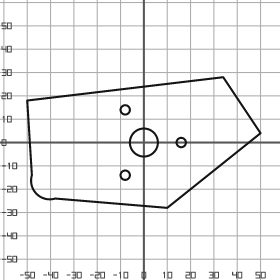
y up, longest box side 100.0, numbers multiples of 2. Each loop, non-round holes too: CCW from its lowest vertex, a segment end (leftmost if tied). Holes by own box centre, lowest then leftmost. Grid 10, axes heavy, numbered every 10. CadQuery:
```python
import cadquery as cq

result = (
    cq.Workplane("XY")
    .moveTo(10.0, -28.0)
    .lineTo(50.0, 4.0)
    .lineTo(34.0, 28.0)
    .lineTo(-50.0, 18.0)
    .lineTo(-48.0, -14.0)
    .threePointArc((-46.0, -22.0), (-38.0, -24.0))
    .close()
    .moveTo(-8.0, -14.0)
    .circle(2.0)
    .moveTo(0.0, 0.0)
    .circle(6.0)
    .moveTo(16.0, 0.0)
    .circle(2.0)
    .moveTo(-8.0, 14.0)
    .circle(2.0)
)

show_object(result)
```